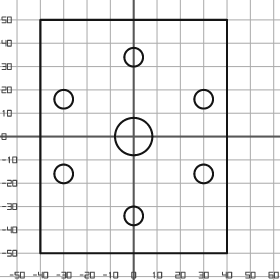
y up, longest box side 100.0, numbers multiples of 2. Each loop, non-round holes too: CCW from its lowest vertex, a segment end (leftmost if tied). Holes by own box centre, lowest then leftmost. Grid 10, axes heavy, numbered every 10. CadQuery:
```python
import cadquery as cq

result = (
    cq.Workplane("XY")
    .moveTo(-40.0, -50.0)
    .lineTo(40.0, -50.0)
    .lineTo(40.0, 50.0)
    .lineTo(-40.0, 50.0)
    .close()
    .moveTo(0.0, -34.0)
    .circle(4.0)
    .moveTo(-30.0, -16.0)
    .circle(4.0)
    .moveTo(30.0, -16.0)
    .circle(4.0)
    .moveTo(0.0, 0.0)
    .circle(8.0)
    .moveTo(-30.0, 16.0)
    .circle(4.0)
    .moveTo(30.0, 16.0)
    .circle(4.0)
    .moveTo(0.0, 34.0)
    .circle(4.0)
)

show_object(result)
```